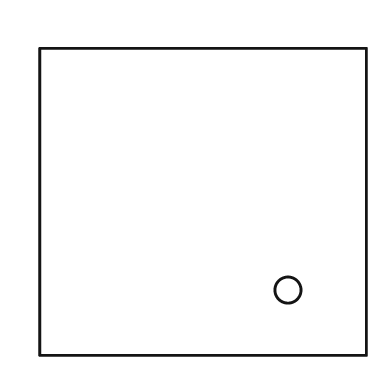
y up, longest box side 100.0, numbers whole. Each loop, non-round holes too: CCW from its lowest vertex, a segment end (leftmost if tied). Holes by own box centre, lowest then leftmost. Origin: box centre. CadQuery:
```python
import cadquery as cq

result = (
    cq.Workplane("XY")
    .moveTo(-50.0, -47.0)
    .lineTo(50.0, -47.0)
    .lineTo(50.0, 47.0)
    .lineTo(-50.0, 47.0)
    .close()
    .moveTo(26.0, -27.0)
    .circle(4.0)
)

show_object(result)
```